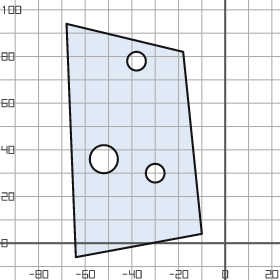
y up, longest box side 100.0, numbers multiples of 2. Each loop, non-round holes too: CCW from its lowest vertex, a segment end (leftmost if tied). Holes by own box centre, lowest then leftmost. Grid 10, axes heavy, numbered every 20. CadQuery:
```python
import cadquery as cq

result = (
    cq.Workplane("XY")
    .moveTo(-64.0, -6.0)
    .lineTo(-10.0, 4.0)
    .lineTo(-18.0, 82.0)
    .lineTo(-68.0, 94.0)
    .close()
    .moveTo(-30.0, 30.0)
    .circle(4.0)
    .moveTo(-52.0, 36.0)
    .circle(6.0)
    .moveTo(-38.0, 78.0)
    .circle(4.0)
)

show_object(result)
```